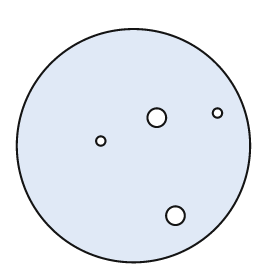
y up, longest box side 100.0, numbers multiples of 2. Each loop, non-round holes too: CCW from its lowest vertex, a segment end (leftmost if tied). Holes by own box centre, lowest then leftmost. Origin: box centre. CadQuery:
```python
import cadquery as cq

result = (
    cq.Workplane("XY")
    .moveTo(0.0, 0.0)
    .circle(50.0)
    .moveTo(18.0, -30.0)
    .circle(4.0)
    .moveTo(-14.0, 2.0)
    .circle(2.0)
    .moveTo(10.0, 12.0)
    .circle(4.0)
    .moveTo(36.0, 14.0)
    .circle(2.0)
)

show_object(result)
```